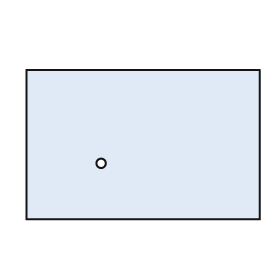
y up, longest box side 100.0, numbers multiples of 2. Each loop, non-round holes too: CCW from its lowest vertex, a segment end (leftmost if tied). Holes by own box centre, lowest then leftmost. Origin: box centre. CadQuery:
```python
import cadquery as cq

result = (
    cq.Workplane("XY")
    .moveTo(-50.0, -32.0)
    .lineTo(50.0, -32.0)
    .lineTo(50.0, 32.0)
    .lineTo(-50.0, 32.0)
    .close()
    .moveTo(-18.0, -8.0)
    .circle(2.0)
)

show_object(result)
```